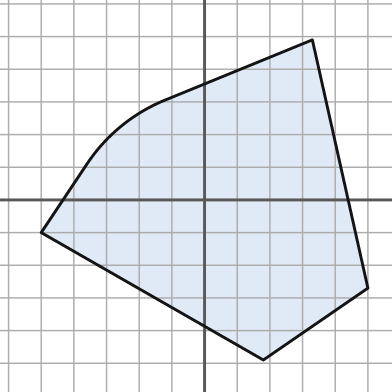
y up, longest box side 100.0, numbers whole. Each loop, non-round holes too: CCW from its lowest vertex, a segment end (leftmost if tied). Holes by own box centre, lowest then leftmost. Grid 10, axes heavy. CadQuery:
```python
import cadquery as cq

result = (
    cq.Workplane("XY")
    .moveTo(18.0, -49.0)
    .lineTo(50.0, -27.0)
    .lineTo(33.0, 49.0)
    .lineTo(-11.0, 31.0)
    .threePointArc((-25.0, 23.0), (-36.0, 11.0))
    .lineTo(-50.0, -10.0)
    .close()
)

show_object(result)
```